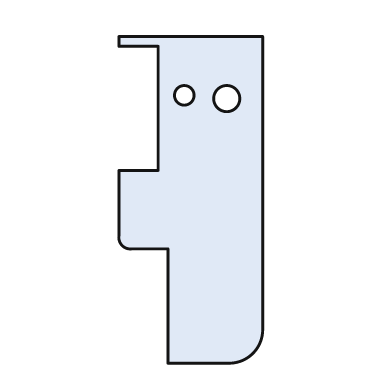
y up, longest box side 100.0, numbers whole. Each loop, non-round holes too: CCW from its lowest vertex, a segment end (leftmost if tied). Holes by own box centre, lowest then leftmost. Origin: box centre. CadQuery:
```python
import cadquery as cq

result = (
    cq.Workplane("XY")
    .moveTo(-7.0, -50.0)
    .lineTo(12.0, -50.0)
    .threePointArc((19.0, -47.0), (22.0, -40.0))
    .lineTo(22.0, 50.0)
    .lineTo(-22.0, 50.0)
    .lineTo(-22.0, 47.0)
    .lineTo(-10.0, 47.0)
    .lineTo(-10.0, 9.0)
    .lineTo(-22.0, 9.0)
    .lineTo(-22.0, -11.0)
    .threePointArc((-21.0, -14.0), (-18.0, -15.0))
    .lineTo(-7.0, -15.0)
    .close()
    .moveTo(11.0, 31.0)
    .circle(4.0)
    .moveTo(-2.0, 32.0)
    .circle(3.0)
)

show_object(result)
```